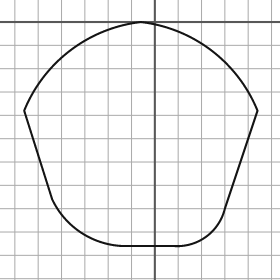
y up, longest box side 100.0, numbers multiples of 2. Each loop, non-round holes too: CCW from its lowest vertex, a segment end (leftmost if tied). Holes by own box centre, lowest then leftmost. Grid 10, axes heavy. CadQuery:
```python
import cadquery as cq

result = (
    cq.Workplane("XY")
    .moveTo(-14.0, -96.0)
    .lineTo(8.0, -96.0)
    .threePointArc((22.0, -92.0), (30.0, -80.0))
    .lineTo(44.0, -38.0)
    .threePointArc((24.0, -12.0), (-6.0, 0.0))
    .threePointArc((-36.0, -12.0), (-56.0, -38.0))
    .lineTo(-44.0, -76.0)
    .threePointArc((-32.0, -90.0), (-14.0, -96.0))
    .close()
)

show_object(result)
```